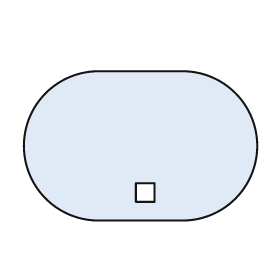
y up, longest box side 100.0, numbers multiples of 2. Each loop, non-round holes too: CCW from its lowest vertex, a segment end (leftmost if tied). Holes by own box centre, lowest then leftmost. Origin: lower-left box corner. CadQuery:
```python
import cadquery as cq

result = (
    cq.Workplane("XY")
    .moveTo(32.0, 0.0)
    .lineTo(68.0, 0.0)
    .threePointArc((100.0, 32.0), (68.0, 64.0))
    .lineTo(32.0, 64.0)
    .threePointArc((0.0, 32.0), (32.0, 0.0))
    .close()
    .moveTo(48.0, 8.0)
    .lineTo(56.0, 8.0)
    .lineTo(56.0, 16.0)
    .lineTo(48.0, 16.0)
    .close()
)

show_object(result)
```